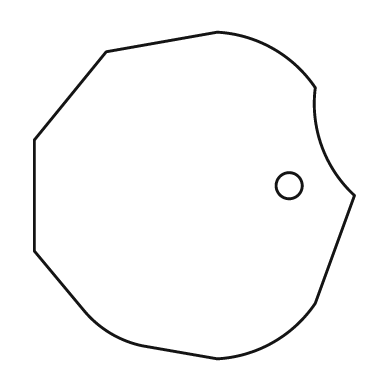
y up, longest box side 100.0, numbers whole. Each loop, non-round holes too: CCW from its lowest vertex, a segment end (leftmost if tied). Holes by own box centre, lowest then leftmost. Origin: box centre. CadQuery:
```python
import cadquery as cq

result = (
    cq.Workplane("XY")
    .moveTo(7.0, -50.0)
    .threePointArc((24.0, -45.0), (37.0, -33.0))
    .lineTo(49.0, 0.0)
    .threePointArc((39.0, 15.0), (37.0, 33.0))
    .threePointArc((24.0, 45.0), (7.0, 50.0))
    .lineTo(-27.0, 44.0)
    .lineTo(-49.0, 17.0)
    .lineTo(-49.0, -17.0)
    .lineTo(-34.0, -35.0)
    .threePointArc((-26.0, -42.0), (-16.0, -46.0))
    .close()
    .moveTo(29.0, 3.0)
    .circle(4.0)
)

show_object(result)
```